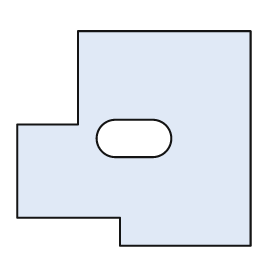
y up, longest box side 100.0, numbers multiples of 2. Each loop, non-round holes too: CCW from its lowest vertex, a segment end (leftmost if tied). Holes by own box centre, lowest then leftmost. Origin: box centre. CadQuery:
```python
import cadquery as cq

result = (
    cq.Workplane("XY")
    .moveTo(-6.0, -46.0)
    .lineTo(50.0, -46.0)
    .lineTo(50.0, 46.0)
    .lineTo(-24.0, 46.0)
    .lineTo(-24.0, 6.0)
    .lineTo(-50.0, 6.0)
    .lineTo(-50.0, -34.0)
    .lineTo(-6.0, -34.0)
    .close()
    .moveTo(-8.0, -8.0)
    .lineTo(8.0, -8.0)
    .threePointArc((16.0, 0.0), (8.0, 8.0))
    .lineTo(-8.0, 8.0)
    .threePointArc((-16.0, 0.0), (-8.0, -8.0))
    .close()
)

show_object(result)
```